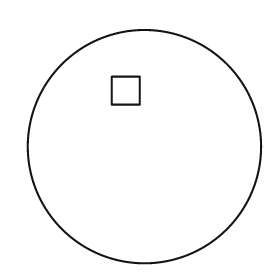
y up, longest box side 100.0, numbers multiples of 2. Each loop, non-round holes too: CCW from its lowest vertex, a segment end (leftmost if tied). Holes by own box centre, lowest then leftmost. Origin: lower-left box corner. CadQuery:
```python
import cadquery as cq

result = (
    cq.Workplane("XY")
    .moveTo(50.0, 50.0)
    .circle(50.0)
    .moveTo(36.0, 68.0)
    .lineTo(48.0, 68.0)
    .lineTo(48.0, 80.0)
    .lineTo(36.0, 80.0)
    .close()
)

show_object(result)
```